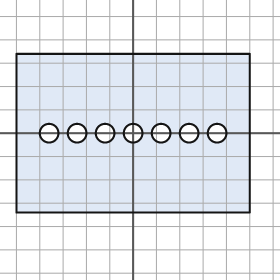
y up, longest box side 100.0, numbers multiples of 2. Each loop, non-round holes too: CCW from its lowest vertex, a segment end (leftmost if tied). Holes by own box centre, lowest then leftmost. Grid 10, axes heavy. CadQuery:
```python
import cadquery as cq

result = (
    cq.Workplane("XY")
    .moveTo(-50.0, -34.0)
    .lineTo(50.0, -34.0)
    .lineTo(50.0, 34.0)
    .lineTo(-50.0, 34.0)
    .close()
    .moveTo(-36.0, 0.0)
    .circle(4.0)
    .moveTo(-24.0, 0.0)
    .circle(4.0)
    .moveTo(-12.0, 0.0)
    .circle(4.0)
    .moveTo(0.0, 0.0)
    .circle(4.0)
    .moveTo(12.0, 0.0)
    .circle(4.0)
    .moveTo(24.0, 0.0)
    .circle(4.0)
    .moveTo(36.0, 0.0)
    .circle(4.0)
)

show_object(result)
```